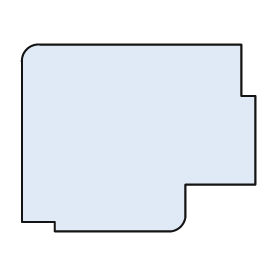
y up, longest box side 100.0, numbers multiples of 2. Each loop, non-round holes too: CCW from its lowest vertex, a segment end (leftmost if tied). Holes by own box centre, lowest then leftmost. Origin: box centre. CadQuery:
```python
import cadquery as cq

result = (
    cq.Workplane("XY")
    .moveTo(-36.0, -40.0)
    .lineTo(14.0, -40.0)
    .threePointArc((18.0, -38.0), (20.0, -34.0))
    .lineTo(20.0, -20.0)
    .lineTo(50.0, -20.0)
    .lineTo(50.0, 18.0)
    .lineTo(44.0, 18.0)
    .lineTo(44.0, 40.0)
    .lineTo(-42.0, 40.0)
    .threePointArc((-48.0, 38.0), (-50.0, 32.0))
    .lineTo(-50.0, -36.0)
    .lineTo(-36.0, -36.0)
    .close()
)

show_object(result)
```